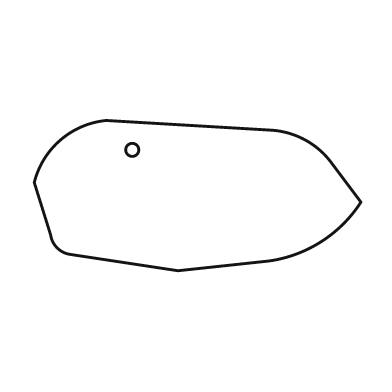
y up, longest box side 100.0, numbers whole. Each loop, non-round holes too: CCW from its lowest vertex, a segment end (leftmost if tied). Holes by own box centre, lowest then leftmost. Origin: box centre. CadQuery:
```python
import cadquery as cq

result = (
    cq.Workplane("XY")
    .moveTo(-6.0, -23.0)
    .lineTo(22.0, -20.0)
    .threePointArc((38.0, -14.0), (50.0, -2.0))
    .lineTo(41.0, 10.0)
    .threePointArc((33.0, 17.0), (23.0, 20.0))
    .lineTo(-28.0, 23.0)
    .threePointArc((-42.0, 17.0), (-50.0, 4.0))
    .lineTo(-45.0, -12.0)
    .threePointArc((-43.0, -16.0), (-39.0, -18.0))
    .close()
    .moveTo(-20.0, 14.0)
    .circle(2.0)
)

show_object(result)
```